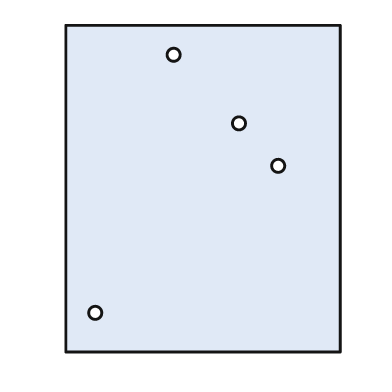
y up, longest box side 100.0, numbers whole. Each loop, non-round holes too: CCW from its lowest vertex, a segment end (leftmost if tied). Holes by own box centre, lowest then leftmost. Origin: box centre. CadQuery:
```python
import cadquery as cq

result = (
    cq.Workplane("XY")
    .moveTo(-42.0, -50.0)
    .lineTo(42.0, -50.0)
    .lineTo(42.0, 50.0)
    .lineTo(-42.0, 50.0)
    .close()
    .moveTo(-33.0, -38.0)
    .circle(2.0)
    .moveTo(23.0, 7.0)
    .circle(2.0)
    .moveTo(11.0, 20.0)
    .circle(2.0)
    .moveTo(-9.0, 41.0)
    .circle(2.0)
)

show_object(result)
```